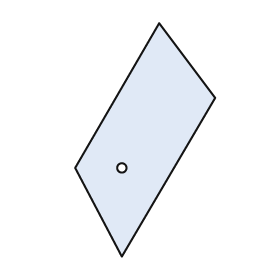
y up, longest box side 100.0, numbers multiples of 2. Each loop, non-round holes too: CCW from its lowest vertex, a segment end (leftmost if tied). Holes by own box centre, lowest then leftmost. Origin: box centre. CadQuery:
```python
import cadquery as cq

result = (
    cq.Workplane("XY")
    .moveTo(-10.0, -50.0)
    .lineTo(30.0, 18.0)
    .lineTo(6.0, 50.0)
    .lineTo(-30.0, -12.0)
    .close()
    .moveTo(-10.0, -12.0)
    .circle(2.0)
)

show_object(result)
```